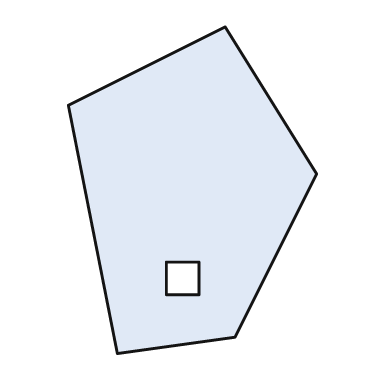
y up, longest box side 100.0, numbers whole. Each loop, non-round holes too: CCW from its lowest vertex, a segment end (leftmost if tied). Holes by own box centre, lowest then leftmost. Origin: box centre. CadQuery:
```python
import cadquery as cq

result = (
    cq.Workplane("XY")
    .moveTo(-23.0, -50.0)
    .lineTo(13.0, -45.0)
    .lineTo(38.0, 5.0)
    .lineTo(10.0, 50.0)
    .lineTo(-38.0, 26.0)
    .close()
    .moveTo(-8.0, -32.0)
    .lineTo(2.0, -32.0)
    .lineTo(2.0, -22.0)
    .lineTo(-8.0, -22.0)
    .close()
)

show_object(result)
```